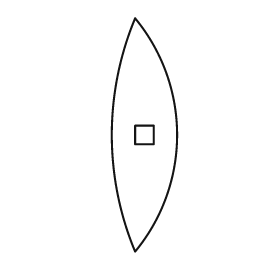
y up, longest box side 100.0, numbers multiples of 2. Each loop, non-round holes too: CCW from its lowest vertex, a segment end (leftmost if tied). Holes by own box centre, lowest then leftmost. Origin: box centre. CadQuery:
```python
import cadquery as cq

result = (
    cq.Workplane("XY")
    .moveTo(-4.0, -50.0)
    .threePointArc((14.0, 0.0), (-4.0, 50.0))
    .threePointArc((-14.0, 0.0), (-4.0, -50.0))
    .close()
    .moveTo(-4.0, -4.0)
    .lineTo(4.0, -4.0)
    .lineTo(4.0, 4.0)
    .lineTo(-4.0, 4.0)
    .close()
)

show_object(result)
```